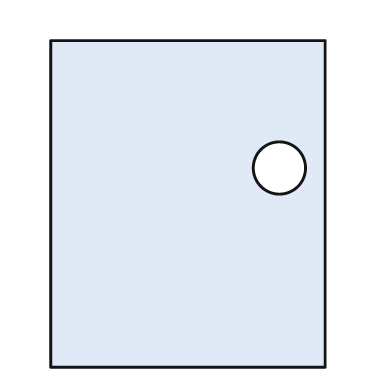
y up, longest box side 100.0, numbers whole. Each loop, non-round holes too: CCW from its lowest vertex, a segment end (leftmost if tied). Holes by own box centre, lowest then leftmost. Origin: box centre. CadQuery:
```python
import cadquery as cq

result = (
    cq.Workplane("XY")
    .moveTo(-42.0, -50.0)
    .lineTo(42.0, -50.0)
    .lineTo(42.0, 50.0)
    .lineTo(-42.0, 50.0)
    .close()
    .moveTo(28.0, 11.0)
    .circle(8.0)
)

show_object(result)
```